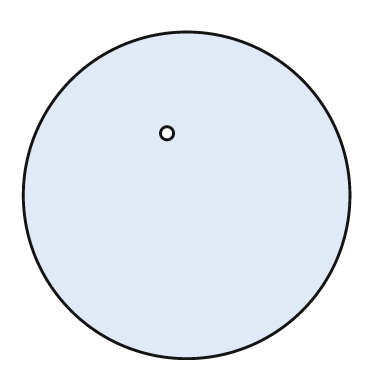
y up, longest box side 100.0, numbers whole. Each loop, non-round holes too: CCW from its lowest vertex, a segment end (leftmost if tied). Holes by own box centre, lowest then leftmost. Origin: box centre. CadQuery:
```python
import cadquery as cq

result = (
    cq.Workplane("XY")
    .moveTo(0.0, 0.0)
    .circle(50.0)
    .moveTo(-6.0, 19.0)
    .circle(2.0)
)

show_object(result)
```